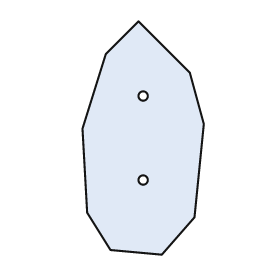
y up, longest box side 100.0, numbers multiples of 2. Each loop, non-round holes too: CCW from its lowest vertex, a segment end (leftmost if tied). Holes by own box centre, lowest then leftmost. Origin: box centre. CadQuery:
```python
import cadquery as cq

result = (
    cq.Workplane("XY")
    .moveTo(8.0, -50.0)
    .lineTo(22.0, -34.0)
    .lineTo(26.0, 6.0)
    .lineTo(20.0, 28.0)
    .lineTo(-2.0, 50.0)
    .lineTo(-16.0, 36.0)
    .lineTo(-26.0, 4.0)
    .lineTo(-24.0, -32.0)
    .lineTo(-14.0, -48.0)
    .close()
    .moveTo(0.0, -18.0)
    .circle(2.0)
    .moveTo(0.0, 18.0)
    .circle(2.0)
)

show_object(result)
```